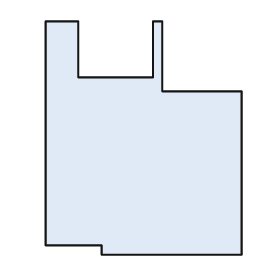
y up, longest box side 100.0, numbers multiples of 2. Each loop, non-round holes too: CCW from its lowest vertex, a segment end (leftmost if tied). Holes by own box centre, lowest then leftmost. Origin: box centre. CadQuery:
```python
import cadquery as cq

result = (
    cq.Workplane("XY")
    .moveTo(-18.0, -50.0)
    .lineTo(42.0, -50.0)
    .lineTo(42.0, 20.0)
    .lineTo(8.0, 20.0)
    .lineTo(8.0, 50.0)
    .lineTo(4.0, 50.0)
    .lineTo(4.0, 26.0)
    .lineTo(-28.0, 26.0)
    .lineTo(-28.0, 50.0)
    .lineTo(-42.0, 50.0)
    .lineTo(-42.0, -46.0)
    .lineTo(-18.0, -46.0)
    .close()
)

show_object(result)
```